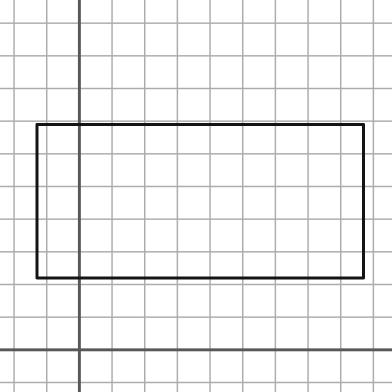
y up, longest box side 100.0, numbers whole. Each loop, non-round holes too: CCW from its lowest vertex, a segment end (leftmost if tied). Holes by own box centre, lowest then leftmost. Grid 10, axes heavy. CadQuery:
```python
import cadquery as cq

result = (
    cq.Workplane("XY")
    .moveTo(-13.0, 22.0)
    .lineTo(87.0, 22.0)
    .lineTo(87.0, 69.0)
    .lineTo(-13.0, 69.0)
    .close()
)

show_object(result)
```